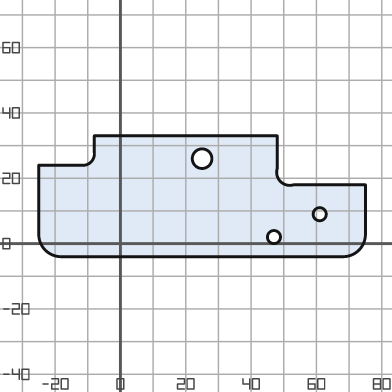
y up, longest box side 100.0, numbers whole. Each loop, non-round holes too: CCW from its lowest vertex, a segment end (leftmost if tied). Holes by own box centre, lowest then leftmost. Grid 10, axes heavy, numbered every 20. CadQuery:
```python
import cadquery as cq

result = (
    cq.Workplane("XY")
    .moveTo(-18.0, -4.0)
    .lineTo(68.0, -4.0)
    .threePointArc((73.0, -2.0), (75.0, 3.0))
    .lineTo(75.0, 18.0)
    .lineTo(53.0, 18.0)
    .threePointArc((49.0, 19.0), (48.0, 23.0))
    .lineTo(48.0, 33.0)
    .lineTo(-8.0, 33.0)
    .lineTo(-8.0, 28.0)
    .threePointArc((-9.0, 25.0), (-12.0, 24.0))
    .lineTo(-25.0, 24.0)
    .lineTo(-25.0, 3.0)
    .threePointArc((-23.0, -2.0), (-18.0, -4.0))
    .close()
    .moveTo(47.0, 2.0)
    .circle(2.0)
    .moveTo(61.0, 9.0)
    .circle(2.0)
    .moveTo(25.0, 26.0)
    .circle(3.0)
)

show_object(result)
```